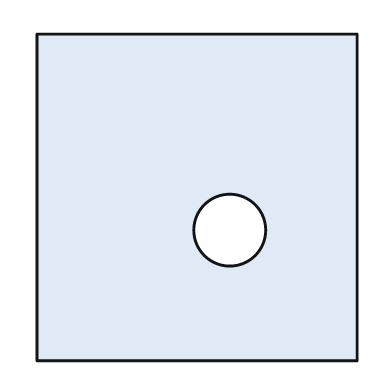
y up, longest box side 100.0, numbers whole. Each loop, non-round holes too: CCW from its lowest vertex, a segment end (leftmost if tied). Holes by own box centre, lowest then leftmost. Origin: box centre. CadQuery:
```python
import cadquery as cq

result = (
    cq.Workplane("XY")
    .moveTo(-49.0, -50.0)
    .lineTo(49.0, -50.0)
    .lineTo(49.0, 50.0)
    .lineTo(-49.0, 50.0)
    .close()
    .moveTo(10.0, -10.0)
    .circle(11.0)
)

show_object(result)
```